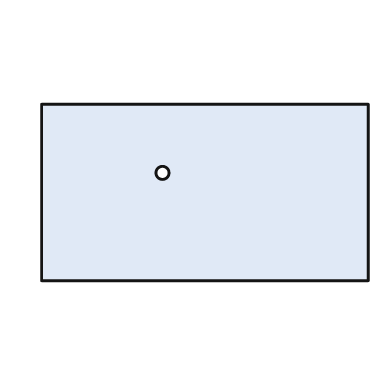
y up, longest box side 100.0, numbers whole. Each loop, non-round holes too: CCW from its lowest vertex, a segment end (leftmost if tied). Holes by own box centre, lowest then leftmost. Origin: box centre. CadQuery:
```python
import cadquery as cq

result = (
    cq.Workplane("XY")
    .moveTo(-50.0, -27.0)
    .lineTo(50.0, -27.0)
    .lineTo(50.0, 27.0)
    .lineTo(-50.0, 27.0)
    .close()
    .moveTo(-13.0, 6.0)
    .circle(2.0)
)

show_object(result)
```